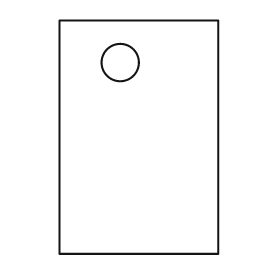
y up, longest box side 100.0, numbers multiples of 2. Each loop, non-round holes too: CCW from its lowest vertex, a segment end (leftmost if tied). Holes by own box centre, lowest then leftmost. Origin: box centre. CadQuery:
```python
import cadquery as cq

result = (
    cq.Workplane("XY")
    .moveTo(-34.0, -50.0)
    .lineTo(34.0, -50.0)
    .lineTo(34.0, 50.0)
    .lineTo(-34.0, 50.0)
    .close()
    .moveTo(-8.0, 32.0)
    .circle(8.0)
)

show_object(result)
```